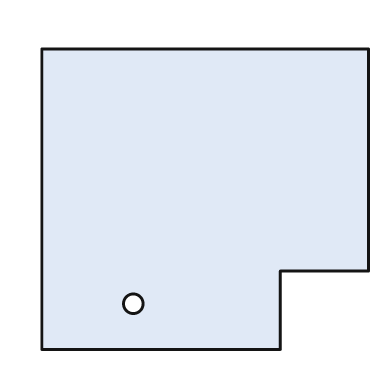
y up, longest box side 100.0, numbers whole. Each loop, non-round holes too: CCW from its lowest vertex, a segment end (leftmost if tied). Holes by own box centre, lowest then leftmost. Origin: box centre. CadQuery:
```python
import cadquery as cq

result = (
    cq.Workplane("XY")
    .moveTo(-50.0, -46.0)
    .lineTo(23.0, -46.0)
    .lineTo(23.0, -22.0)
    .lineTo(50.0, -22.0)
    .lineTo(50.0, 46.0)
    .lineTo(-50.0, 46.0)
    .close()
    .moveTo(-22.0, -32.0)
    .circle(3.0)
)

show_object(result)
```